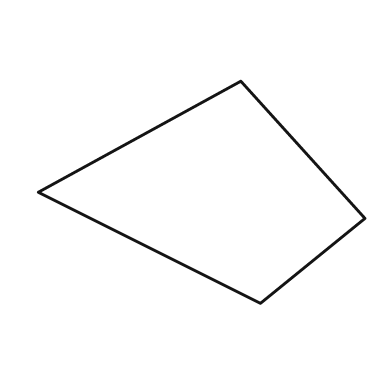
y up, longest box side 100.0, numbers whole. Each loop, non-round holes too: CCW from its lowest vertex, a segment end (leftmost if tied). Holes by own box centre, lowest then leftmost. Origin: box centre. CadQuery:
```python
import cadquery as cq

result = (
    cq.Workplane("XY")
    .moveTo(18.0, -34.0)
    .lineTo(50.0, -8.0)
    .lineTo(12.0, 34.0)
    .lineTo(-50.0, 0.0)
    .close()
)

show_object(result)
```